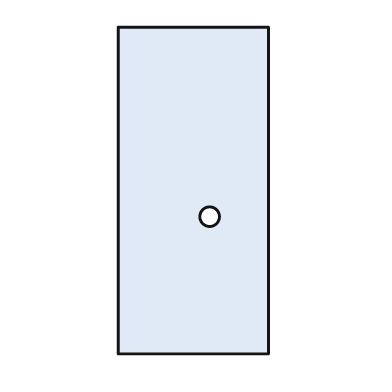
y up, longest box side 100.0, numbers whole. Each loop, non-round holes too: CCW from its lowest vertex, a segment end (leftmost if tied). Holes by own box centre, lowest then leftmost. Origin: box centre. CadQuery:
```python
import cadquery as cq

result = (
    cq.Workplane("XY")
    .moveTo(-23.0, -50.0)
    .lineTo(23.0, -50.0)
    .lineTo(23.0, 50.0)
    .lineTo(-23.0, 50.0)
    .close()
    .moveTo(5.0, -8.0)
    .circle(3.0)
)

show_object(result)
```